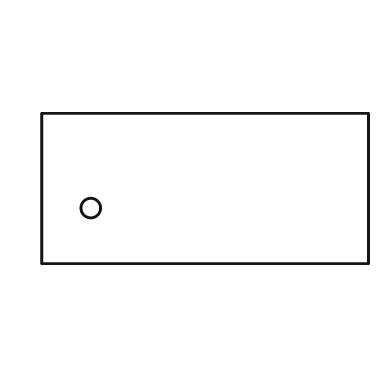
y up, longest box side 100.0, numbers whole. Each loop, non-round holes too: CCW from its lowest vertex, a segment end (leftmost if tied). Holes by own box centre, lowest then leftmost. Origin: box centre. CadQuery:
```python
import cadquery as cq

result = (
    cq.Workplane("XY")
    .moveTo(-50.0, -23.0)
    .lineTo(50.0, -23.0)
    .lineTo(50.0, 23.0)
    .lineTo(-50.0, 23.0)
    .close()
    .moveTo(-35.0, -6.0)
    .circle(3.0)
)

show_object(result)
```